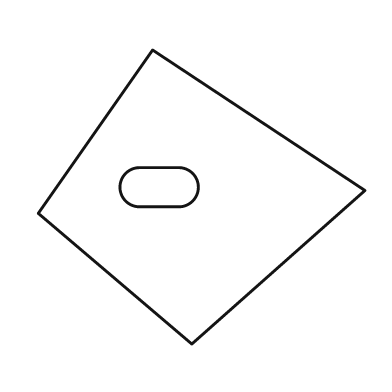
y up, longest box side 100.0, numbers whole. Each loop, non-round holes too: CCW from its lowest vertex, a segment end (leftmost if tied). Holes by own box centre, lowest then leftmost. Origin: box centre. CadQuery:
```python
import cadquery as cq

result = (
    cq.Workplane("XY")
    .moveTo(-3.0, -45.0)
    .lineTo(50.0, 2.0)
    .lineTo(-15.0, 45.0)
    .lineTo(-50.0, -5.0)
    .close()
    .moveTo(-19.0, -3.0)
    .lineTo(-7.0, -3.0)
    .threePointArc((-1.0, 3.0), (-7.0, 9.0))
    .lineTo(-19.0, 9.0)
    .threePointArc((-25.0, 3.0), (-19.0, -3.0))
    .close()
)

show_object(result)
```